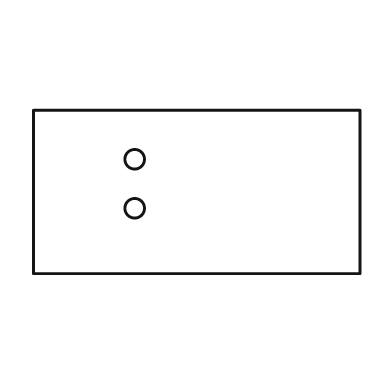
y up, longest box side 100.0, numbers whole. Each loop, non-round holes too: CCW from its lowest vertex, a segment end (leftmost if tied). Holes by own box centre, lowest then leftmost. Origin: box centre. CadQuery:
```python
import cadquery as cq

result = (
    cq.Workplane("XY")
    .moveTo(-50.0, -25.0)
    .lineTo(50.0, -25.0)
    .lineTo(50.0, 25.0)
    .lineTo(-50.0, 25.0)
    .close()
    .moveTo(-19.0, -5.0)
    .circle(3.0)
    .moveTo(-19.0, 10.0)
    .circle(3.0)
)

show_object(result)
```